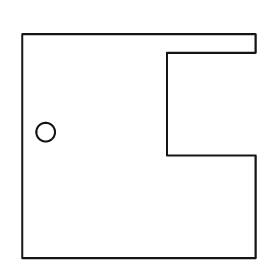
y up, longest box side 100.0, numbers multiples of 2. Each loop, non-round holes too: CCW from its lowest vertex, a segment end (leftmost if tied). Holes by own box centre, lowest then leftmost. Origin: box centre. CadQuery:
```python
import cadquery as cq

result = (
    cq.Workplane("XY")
    .moveTo(-50.0, -48.0)
    .lineTo(50.0, -48.0)
    .lineTo(50.0, -4.0)
    .lineTo(12.0, -4.0)
    .lineTo(12.0, 40.0)
    .lineTo(50.0, 40.0)
    .lineTo(50.0, 48.0)
    .lineTo(-50.0, 48.0)
    .close()
    .moveTo(-40.0, 6.0)
    .circle(4.0)
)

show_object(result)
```